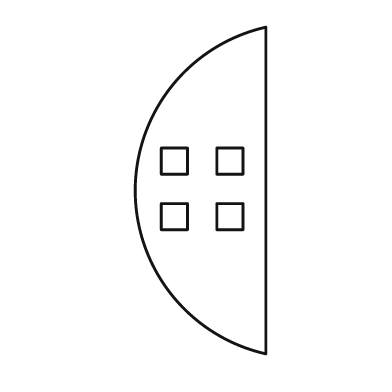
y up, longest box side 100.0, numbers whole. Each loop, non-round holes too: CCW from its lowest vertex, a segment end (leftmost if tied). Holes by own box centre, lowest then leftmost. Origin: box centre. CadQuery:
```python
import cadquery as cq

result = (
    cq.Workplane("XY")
    .moveTo(20.0, -50.0)
    .lineTo(20.0, 50.0)
    .threePointArc((-20.0, 0.0), (20.0, -50.0))
    .close()
    .moveTo(-12.0, -12.0)
    .lineTo(-4.0, -12.0)
    .lineTo(-4.0, -4.0)
    .lineTo(-12.0, -4.0)
    .close()
    .moveTo(5.0, -12.0)
    .lineTo(13.0, -12.0)
    .lineTo(13.0, -4.0)
    .lineTo(5.0, -4.0)
    .close()
    .moveTo(-12.0, 5.0)
    .lineTo(-4.0, 5.0)
    .lineTo(-4.0, 13.0)
    .lineTo(-12.0, 13.0)
    .close()
    .moveTo(5.0, 5.0)
    .lineTo(13.0, 5.0)
    .lineTo(13.0, 13.0)
    .lineTo(5.0, 13.0)
    .close()
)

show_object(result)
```